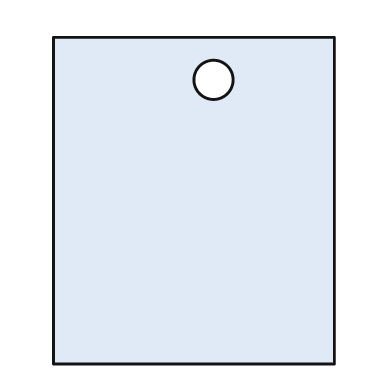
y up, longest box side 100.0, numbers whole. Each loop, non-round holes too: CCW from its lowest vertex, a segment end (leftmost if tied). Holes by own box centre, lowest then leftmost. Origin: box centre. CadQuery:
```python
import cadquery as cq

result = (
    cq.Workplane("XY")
    .moveTo(-43.0, -50.0)
    .lineTo(43.0, -50.0)
    .lineTo(43.0, 50.0)
    .lineTo(-43.0, 50.0)
    .close()
    .moveTo(6.0, 37.0)
    .circle(6.0)
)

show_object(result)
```